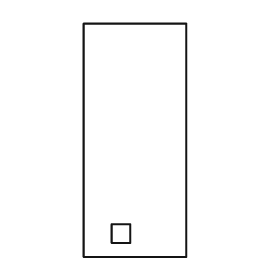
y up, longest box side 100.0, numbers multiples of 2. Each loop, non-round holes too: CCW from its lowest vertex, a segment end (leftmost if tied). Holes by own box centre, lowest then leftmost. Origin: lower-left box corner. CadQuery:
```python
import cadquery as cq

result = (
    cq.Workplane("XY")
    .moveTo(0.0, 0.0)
    .lineTo(44.0, 0.0)
    .lineTo(44.0, 100.0)
    .lineTo(0.0, 100.0)
    .close()
    .moveTo(12.0, 6.0)
    .lineTo(20.0, 6.0)
    .lineTo(20.0, 14.0)
    .lineTo(12.0, 14.0)
    .close()
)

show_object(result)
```